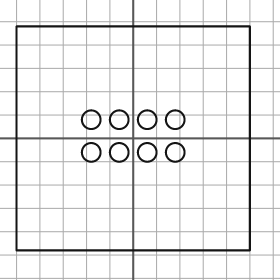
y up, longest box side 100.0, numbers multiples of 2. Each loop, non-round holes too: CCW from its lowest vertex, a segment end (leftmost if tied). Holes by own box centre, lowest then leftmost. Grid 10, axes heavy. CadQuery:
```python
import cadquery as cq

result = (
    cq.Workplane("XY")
    .moveTo(-50.0, -48.0)
    .lineTo(50.0, -48.0)
    .lineTo(50.0, 48.0)
    .lineTo(-50.0, 48.0)
    .close()
    .moveTo(-18.0, -6.0)
    .circle(4.0)
    .moveTo(-6.0, -6.0)
    .circle(4.0)
    .moveTo(6.0, -6.0)
    .circle(4.0)
    .moveTo(18.0, -6.0)
    .circle(4.0)
    .moveTo(-18.0, 8.0)
    .circle(4.0)
    .moveTo(-6.0, 8.0)
    .circle(4.0)
    .moveTo(6.0, 8.0)
    .circle(4.0)
    .moveTo(18.0, 8.0)
    .circle(4.0)
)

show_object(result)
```